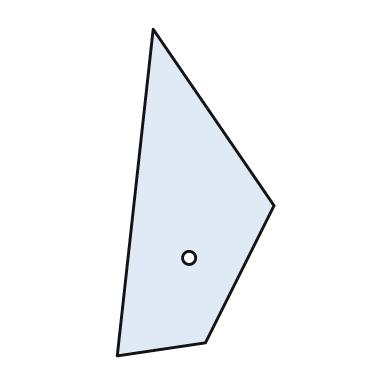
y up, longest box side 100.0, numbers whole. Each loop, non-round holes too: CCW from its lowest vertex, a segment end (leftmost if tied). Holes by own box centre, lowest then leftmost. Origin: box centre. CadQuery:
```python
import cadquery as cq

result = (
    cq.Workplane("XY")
    .moveTo(-24.0, -50.0)
    .lineTo(3.0, -46.0)
    .lineTo(24.0, -4.0)
    .lineTo(-13.0, 50.0)
    .close()
    .moveTo(-2.0, -20.0)
    .circle(2.0)
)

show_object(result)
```